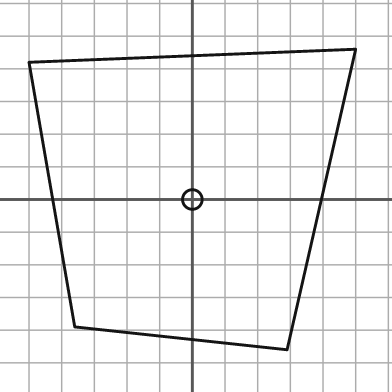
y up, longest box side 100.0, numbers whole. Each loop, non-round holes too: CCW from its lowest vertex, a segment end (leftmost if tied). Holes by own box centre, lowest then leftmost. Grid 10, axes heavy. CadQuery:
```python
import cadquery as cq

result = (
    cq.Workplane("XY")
    .moveTo(29.0, -46.0)
    .lineTo(50.0, 46.0)
    .lineTo(-50.0, 42.0)
    .lineTo(-36.0, -39.0)
    .close()
    .moveTo(0.0, 0.0)
    .circle(3.0)
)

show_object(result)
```